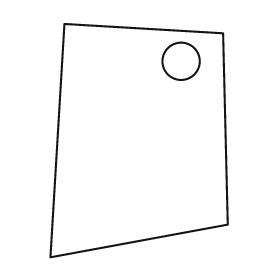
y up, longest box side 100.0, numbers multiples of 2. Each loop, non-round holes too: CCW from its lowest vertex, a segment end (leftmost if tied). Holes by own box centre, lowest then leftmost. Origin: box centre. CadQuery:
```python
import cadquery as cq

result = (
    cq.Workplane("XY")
    .moveTo(-38.0, -50.0)
    .lineTo(38.0, -36.0)
    .lineTo(36.0, 46.0)
    .lineTo(-32.0, 50.0)
    .close()
    .moveTo(18.0, 34.0)
    .circle(8.0)
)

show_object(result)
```